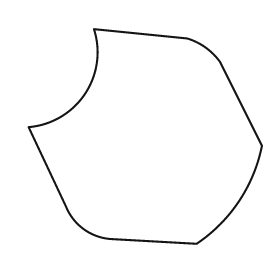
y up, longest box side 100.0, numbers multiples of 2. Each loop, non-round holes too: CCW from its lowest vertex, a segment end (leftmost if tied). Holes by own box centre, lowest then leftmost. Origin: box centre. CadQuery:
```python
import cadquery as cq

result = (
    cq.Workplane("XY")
    .moveTo(22.0, -46.0)
    .threePointArc((40.0, -28.0), (50.0, -4.0))
    .lineTo(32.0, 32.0)
    .threePointArc((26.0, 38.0), (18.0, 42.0))
    .lineTo(-22.0, 46.0)
    .threePointArc((-26.0, 18.0), (-50.0, 4.0))
    .lineTo(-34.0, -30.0)
    .threePointArc((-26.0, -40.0), (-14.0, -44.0))
    .close()
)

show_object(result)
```